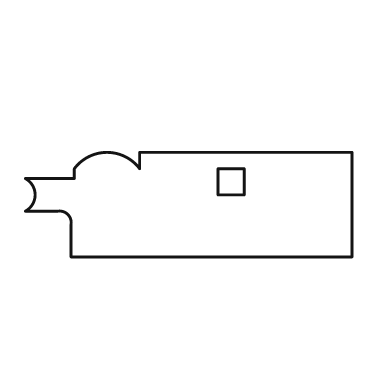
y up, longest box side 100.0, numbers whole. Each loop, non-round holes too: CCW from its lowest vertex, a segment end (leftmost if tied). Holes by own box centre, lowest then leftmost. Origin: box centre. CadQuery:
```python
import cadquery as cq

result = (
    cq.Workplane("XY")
    .moveTo(-36.0, -16.0)
    .lineTo(50.0, -16.0)
    .lineTo(50.0, 16.0)
    .lineTo(-15.0, 16.0)
    .lineTo(-15.0, 11.0)
    .threePointArc((-25.0, 16.0), (-35.0, 11.0))
    .lineTo(-35.0, 8.0)
    .lineTo(-50.0, 8.0)
    .threePointArc((-47.0, 3.0), (-50.0, -2.0))
    .lineTo(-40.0, -2.0)
    .threePointArc((-37.0, -3.0), (-36.0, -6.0))
    .close()
    .moveTo(9.0, 3.0)
    .lineTo(17.0, 3.0)
    .lineTo(17.0, 11.0)
    .lineTo(9.0, 11.0)
    .close()
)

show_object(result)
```